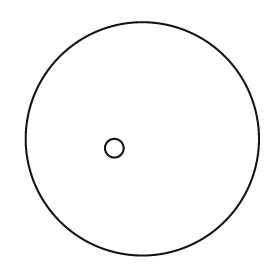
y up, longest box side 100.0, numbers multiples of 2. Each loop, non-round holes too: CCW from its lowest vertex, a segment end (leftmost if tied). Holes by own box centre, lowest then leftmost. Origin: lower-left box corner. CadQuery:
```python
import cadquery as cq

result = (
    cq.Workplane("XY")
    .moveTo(50.0, 50.0)
    .circle(50.0)
    .moveTo(38.0, 46.0)
    .circle(4.0)
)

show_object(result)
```